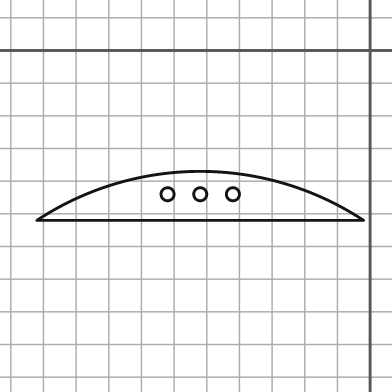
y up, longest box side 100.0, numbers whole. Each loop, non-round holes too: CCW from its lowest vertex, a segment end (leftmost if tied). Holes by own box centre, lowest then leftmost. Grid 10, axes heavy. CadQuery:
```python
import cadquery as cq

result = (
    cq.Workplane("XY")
    .moveTo(-102.0, -52.0)
    .lineTo(-2.0, -52.0)
    .threePointArc((-52.0, -37.0), (-102.0, -52.0))
    .close()
    .moveTo(-62.0, -44.0)
    .circle(2.0)
    .moveTo(-52.0, -44.0)
    .circle(2.0)
    .moveTo(-42.0, -44.0)
    .circle(2.0)
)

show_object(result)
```